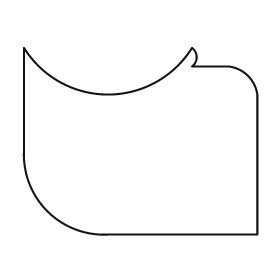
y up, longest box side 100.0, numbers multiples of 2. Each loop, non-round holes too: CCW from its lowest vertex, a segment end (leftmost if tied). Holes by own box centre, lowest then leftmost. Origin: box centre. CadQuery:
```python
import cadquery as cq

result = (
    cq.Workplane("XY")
    .moveTo(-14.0, -40.0)
    .lineTo(50.0, -40.0)
    .lineTo(50.0, 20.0)
    .threePointArc((46.0, 28.0), (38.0, 32.0))
    .lineTo(22.0, 32.0)
    .threePointArc((24.0, 36.0), (22.0, 40.0))
    .threePointArc((-14.0, 20.0), (-50.0, 40.0))
    .lineTo(-50.0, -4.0)
    .threePointArc((-40.0, -30.0), (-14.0, -40.0))
    .close()
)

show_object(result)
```